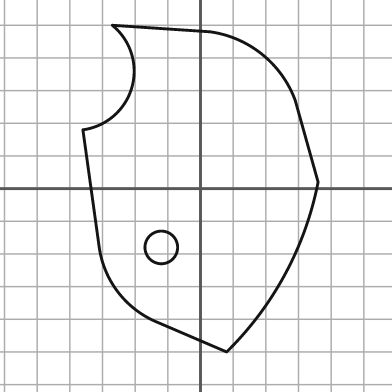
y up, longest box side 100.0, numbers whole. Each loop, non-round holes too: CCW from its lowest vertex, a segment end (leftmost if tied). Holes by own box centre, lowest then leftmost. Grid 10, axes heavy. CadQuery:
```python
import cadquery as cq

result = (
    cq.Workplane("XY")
    .moveTo(8.0, -50.0)
    .threePointArc((26.0, -26.0), (36.0, 2.0))
    .lineTo(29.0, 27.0)
    .threePointArc((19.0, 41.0), (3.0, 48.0))
    .lineTo(-27.0, 50.0)
    .threePointArc((-21.0, 31.0), (-36.0, 18.0))
    .lineTo(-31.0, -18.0)
    .threePointArc((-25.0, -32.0), (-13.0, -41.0))
    .close()
    .moveTo(-12.0, -18.0)
    .circle(5.0)
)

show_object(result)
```